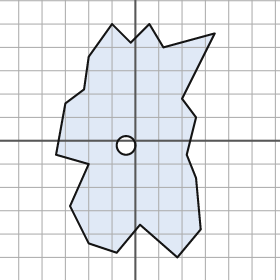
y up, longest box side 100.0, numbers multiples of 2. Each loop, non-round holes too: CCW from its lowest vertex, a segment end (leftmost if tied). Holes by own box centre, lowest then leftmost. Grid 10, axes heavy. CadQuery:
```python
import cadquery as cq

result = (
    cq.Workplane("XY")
    .moveTo(18.0, -50.0)
    .lineTo(28.0, -38.0)
    .lineTo(26.0, -16.0)
    .lineTo(22.0, -6.0)
    .lineTo(26.0, 10.0)
    .lineTo(20.0, 18.0)
    .lineTo(34.0, 46.0)
    .lineTo(12.0, 40.0)
    .lineTo(6.0, 50.0)
    .lineTo(-2.0, 42.0)
    .lineTo(-10.0, 50.0)
    .lineTo(-20.0, 36.0)
    .lineTo(-22.0, 22.0)
    .lineTo(-30.0, 16.0)
    .lineTo(-34.0, -6.0)
    .lineTo(-20.0, -10.0)
    .lineTo(-28.0, -28.0)
    .lineTo(-20.0, -44.0)
    .lineTo(-8.0, -48.0)
    .lineTo(2.0, -36.0)
    .close()
    .moveTo(-4.0, -2.0)
    .circle(4.0)
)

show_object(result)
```